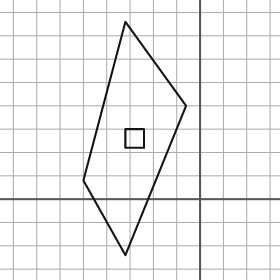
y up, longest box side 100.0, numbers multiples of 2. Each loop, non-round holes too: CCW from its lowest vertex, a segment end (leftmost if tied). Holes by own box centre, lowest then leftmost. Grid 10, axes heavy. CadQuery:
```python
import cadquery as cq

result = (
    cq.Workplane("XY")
    .moveTo(-32.0, -24.0)
    .lineTo(-6.0, 40.0)
    .lineTo(-32.0, 76.0)
    .lineTo(-50.0, 8.0)
    .close()
    .moveTo(-32.0, 22.0)
    .lineTo(-24.0, 22.0)
    .lineTo(-24.0, 30.0)
    .lineTo(-32.0, 30.0)
    .close()
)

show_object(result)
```